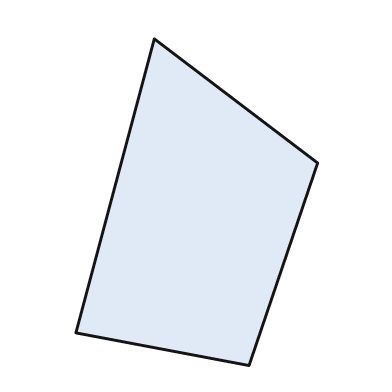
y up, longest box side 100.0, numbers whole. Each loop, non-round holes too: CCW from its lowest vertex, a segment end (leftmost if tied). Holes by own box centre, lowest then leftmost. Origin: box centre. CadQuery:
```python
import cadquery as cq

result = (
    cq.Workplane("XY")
    .moveTo(16.0, -50.0)
    .lineTo(37.0, 12.0)
    .lineTo(-13.0, 50.0)
    .lineTo(-37.0, -40.0)
    .close()
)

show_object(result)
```